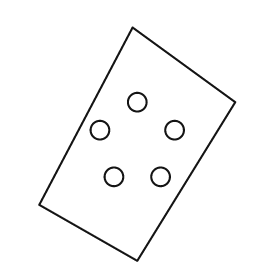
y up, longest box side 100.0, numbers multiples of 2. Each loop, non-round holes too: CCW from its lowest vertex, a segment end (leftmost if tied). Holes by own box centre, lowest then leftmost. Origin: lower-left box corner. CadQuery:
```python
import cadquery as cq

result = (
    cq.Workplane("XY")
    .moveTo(42.0, 0.0)
    .lineTo(84.0, 68.0)
    .lineTo(40.0, 100.0)
    .lineTo(0.0, 24.0)
    .close()
    .moveTo(32.0, 36.0)
    .circle(4.0)
    .moveTo(52.0, 36.0)
    .circle(4.0)
    .moveTo(26.0, 56.0)
    .circle(4.0)
    .moveTo(58.0, 56.0)
    .circle(4.0)
    .moveTo(42.0, 68.0)
    .circle(4.0)
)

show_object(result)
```